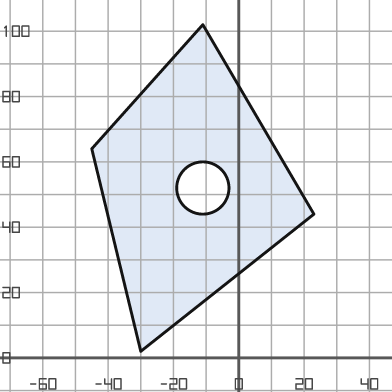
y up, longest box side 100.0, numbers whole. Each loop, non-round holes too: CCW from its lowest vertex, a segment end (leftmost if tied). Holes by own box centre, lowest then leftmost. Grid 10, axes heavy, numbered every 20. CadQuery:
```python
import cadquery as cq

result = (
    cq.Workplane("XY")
    .moveTo(-30.0, 2.0)
    .lineTo(23.0, 44.0)
    .lineTo(-11.0, 102.0)
    .lineTo(-45.0, 64.0)
    .close()
    .moveTo(-11.0, 52.0)
    .circle(8.0)
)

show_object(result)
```